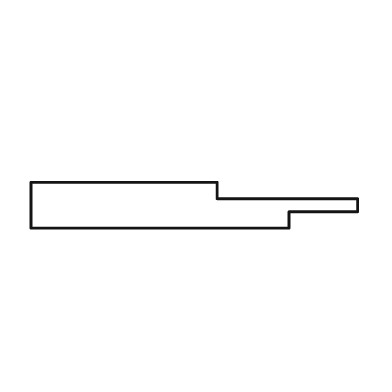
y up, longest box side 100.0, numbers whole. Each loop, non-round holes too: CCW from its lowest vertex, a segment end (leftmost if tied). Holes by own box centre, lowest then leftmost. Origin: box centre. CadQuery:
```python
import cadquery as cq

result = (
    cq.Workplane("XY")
    .moveTo(-50.0, -7.0)
    .lineTo(29.0, -7.0)
    .lineTo(29.0, -2.0)
    .lineTo(50.0, -2.0)
    .lineTo(50.0, 2.0)
    .lineTo(7.0, 2.0)
    .lineTo(7.0, 7.0)
    .lineTo(-50.0, 7.0)
    .close()
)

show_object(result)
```